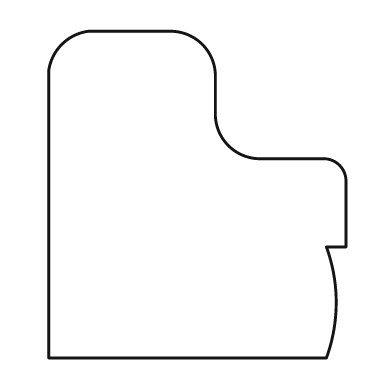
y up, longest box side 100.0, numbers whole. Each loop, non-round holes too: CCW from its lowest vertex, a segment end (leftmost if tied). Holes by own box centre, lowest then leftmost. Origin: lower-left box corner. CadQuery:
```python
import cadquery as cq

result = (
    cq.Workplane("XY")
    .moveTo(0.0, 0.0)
    .lineTo(85.0, 0.0)
    .threePointArc((88.0, 17.0), (85.0, 34.0))
    .lineTo(91.0, 34.0)
    .lineTo(91.0, 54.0)
    .threePointArc((89.0, 59.0), (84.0, 61.0))
    .lineTo(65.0, 61.0)
    .threePointArc((55.0, 65.0), (51.0, 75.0))
    .lineTo(51.0, 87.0)
    .threePointArc((47.0, 96.0), (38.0, 100.0))
    .lineTo(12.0, 100.0)
    .threePointArc((4.0, 96.0), (0.0, 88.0))
    .close()
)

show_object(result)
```